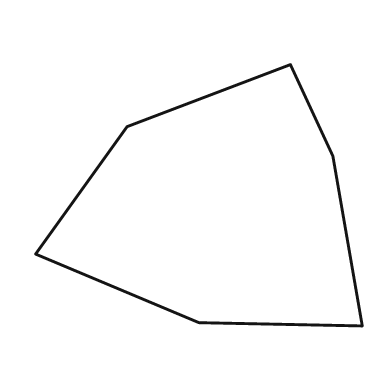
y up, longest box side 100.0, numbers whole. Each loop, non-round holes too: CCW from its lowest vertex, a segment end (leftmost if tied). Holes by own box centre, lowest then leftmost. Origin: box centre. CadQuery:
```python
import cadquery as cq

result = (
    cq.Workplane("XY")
    .moveTo(50.0, -40.0)
    .lineTo(41.0, 12.0)
    .lineTo(28.0, 40.0)
    .lineTo(-22.0, 21.0)
    .lineTo(-50.0, -18.0)
    .lineTo(0.0, -39.0)
    .close()
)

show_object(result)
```